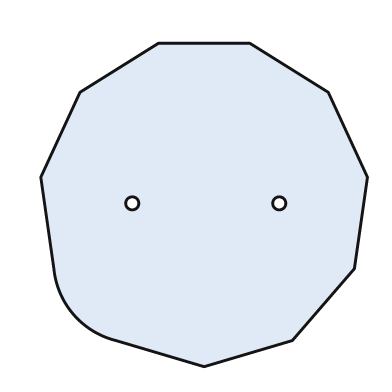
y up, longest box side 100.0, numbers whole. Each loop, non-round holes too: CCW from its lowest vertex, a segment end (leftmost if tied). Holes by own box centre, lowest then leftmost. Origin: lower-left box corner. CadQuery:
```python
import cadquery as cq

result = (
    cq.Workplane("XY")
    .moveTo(50.0, 0.0)
    .lineTo(77.0, 8.0)
    .lineTo(96.0, 30.0)
    .lineTo(100.0, 58.0)
    .lineTo(88.0, 84.0)
    .lineTo(64.0, 99.0)
    .lineTo(36.0, 99.0)
    .lineTo(12.0, 84.0)
    .lineTo(0.0, 58.0)
    .lineTo(4.0, 30.0)
    .threePointArc((10.0, 16.0), (23.0, 8.0))
    .close()
    .moveTo(28.0, 50.0)
    .circle(2.0)
    .moveTo(73.0, 50.0)
    .circle(2.0)
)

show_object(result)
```